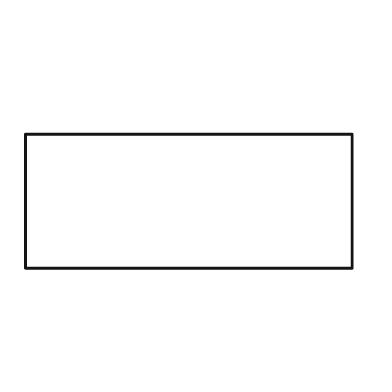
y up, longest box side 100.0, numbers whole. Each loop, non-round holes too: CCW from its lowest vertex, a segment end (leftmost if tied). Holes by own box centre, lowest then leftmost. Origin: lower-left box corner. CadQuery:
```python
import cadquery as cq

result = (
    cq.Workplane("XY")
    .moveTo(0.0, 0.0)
    .lineTo(100.0, 0.0)
    .lineTo(100.0, 41.0)
    .lineTo(0.0, 41.0)
    .close()
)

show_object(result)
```